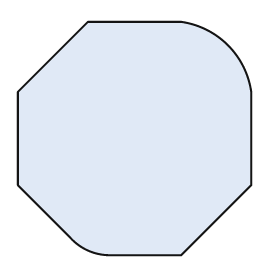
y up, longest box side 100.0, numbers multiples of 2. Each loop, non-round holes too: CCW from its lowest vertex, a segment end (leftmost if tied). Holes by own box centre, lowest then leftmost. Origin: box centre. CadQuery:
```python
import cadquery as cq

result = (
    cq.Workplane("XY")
    .moveTo(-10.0, -50.0)
    .lineTo(20.0, -50.0)
    .lineTo(50.0, -20.0)
    .lineTo(50.0, 20.0)
    .threePointArc((40.0, 40.0), (20.0, 50.0))
    .lineTo(-20.0, 50.0)
    .lineTo(-50.0, 20.0)
    .lineTo(-50.0, -20.0)
    .lineTo(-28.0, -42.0)
    .threePointArc((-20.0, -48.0), (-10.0, -50.0))
    .close()
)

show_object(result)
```